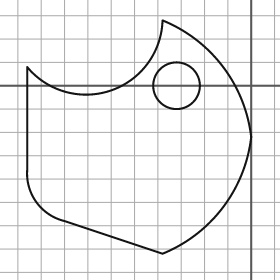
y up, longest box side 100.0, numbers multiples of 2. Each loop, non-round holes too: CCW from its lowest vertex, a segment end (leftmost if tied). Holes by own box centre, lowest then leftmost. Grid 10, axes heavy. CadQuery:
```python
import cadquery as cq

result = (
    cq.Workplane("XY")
    .moveTo(-38.0, -72.0)
    .threePointArc((-12.0, -52.0), (0.0, -22.0))
    .threePointArc((-12.0, 8.0), (-38.0, 28.0))
    .threePointArc((-60.0, -2.0), (-96.0, 8.0))
    .lineTo(-96.0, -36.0)
    .threePointArc((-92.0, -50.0), (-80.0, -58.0))
    .close()
    .moveTo(-32.0, 0.0)
    .circle(10.0)
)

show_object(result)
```